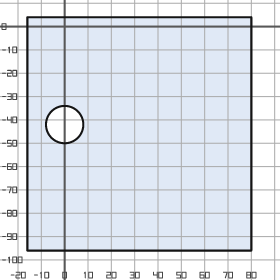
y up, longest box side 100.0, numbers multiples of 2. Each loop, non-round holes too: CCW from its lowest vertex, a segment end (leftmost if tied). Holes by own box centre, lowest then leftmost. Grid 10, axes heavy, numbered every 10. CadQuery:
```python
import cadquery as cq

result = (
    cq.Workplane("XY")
    .moveTo(-16.0, -96.0)
    .lineTo(80.0, -96.0)
    .lineTo(80.0, 4.0)
    .lineTo(-16.0, 4.0)
    .close()
    .moveTo(0.0, -42.0)
    .circle(8.0)
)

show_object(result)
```